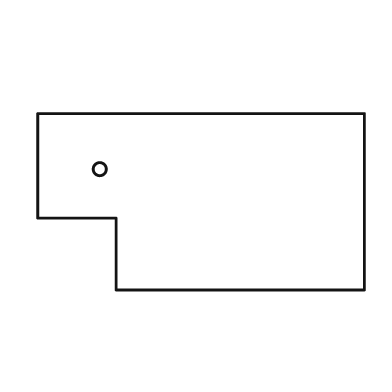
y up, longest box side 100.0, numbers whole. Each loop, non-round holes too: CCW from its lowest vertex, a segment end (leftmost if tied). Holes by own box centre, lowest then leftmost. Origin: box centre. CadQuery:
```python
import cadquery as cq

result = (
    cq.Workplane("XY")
    .moveTo(-26.0, -27.0)
    .lineTo(50.0, -27.0)
    .lineTo(50.0, 27.0)
    .lineTo(-50.0, 27.0)
    .lineTo(-50.0, -5.0)
    .lineTo(-26.0, -5.0)
    .close()
    .moveTo(-31.0, 10.0)
    .circle(2.0)
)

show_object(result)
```